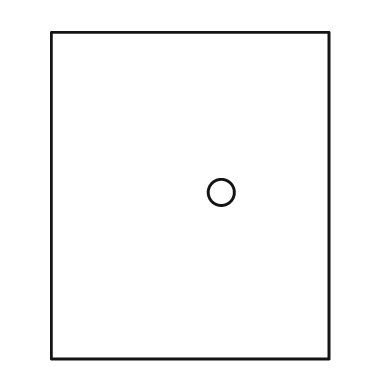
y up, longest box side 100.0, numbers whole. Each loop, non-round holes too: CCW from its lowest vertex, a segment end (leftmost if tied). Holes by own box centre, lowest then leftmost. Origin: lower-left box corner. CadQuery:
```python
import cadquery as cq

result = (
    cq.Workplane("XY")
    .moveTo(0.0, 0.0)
    .lineTo(85.0, 0.0)
    .lineTo(85.0, 100.0)
    .lineTo(0.0, 100.0)
    .close()
    .moveTo(52.0, 51.0)
    .circle(4.0)
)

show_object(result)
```